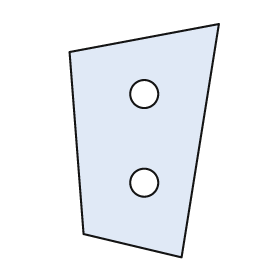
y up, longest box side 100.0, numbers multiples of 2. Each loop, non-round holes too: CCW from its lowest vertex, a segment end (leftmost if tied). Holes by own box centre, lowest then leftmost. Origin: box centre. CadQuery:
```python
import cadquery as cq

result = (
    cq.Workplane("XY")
    .moveTo(16.0, -50.0)
    .lineTo(32.0, 50.0)
    .lineTo(-32.0, 38.0)
    .lineTo(-26.0, -40.0)
    .close()
    .moveTo(0.0, -18.0)
    .circle(6.0)
    .moveTo(0.0, 20.0)
    .circle(6.0)
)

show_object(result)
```